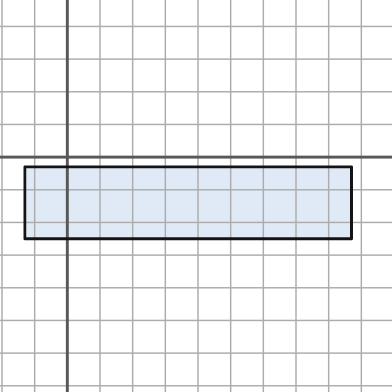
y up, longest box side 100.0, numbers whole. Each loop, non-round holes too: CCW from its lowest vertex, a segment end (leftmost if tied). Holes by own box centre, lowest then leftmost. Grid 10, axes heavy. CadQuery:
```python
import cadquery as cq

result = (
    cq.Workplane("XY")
    .moveTo(-13.0, -25.0)
    .lineTo(87.0, -25.0)
    .lineTo(87.0, -3.0)
    .lineTo(-13.0, -3.0)
    .close()
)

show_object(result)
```